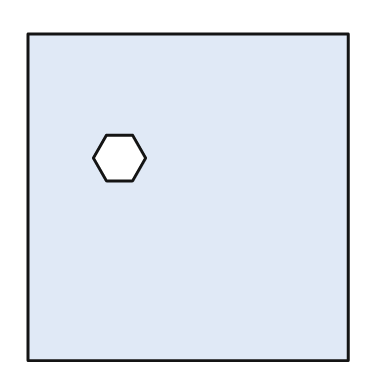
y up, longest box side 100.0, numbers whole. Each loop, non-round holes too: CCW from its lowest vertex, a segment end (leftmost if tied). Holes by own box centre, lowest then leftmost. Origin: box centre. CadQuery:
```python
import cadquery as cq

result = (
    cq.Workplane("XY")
    .moveTo(-49.0, -50.0)
    .lineTo(49.0, -50.0)
    .lineTo(49.0, 50.0)
    .lineTo(-49.0, 50.0)
    .close()
    .moveTo(-25.0, 5.0)
    .lineTo(-17.0, 5.0)
    .lineTo(-13.0, 12.0)
    .lineTo(-17.0, 19.0)
    .lineTo(-25.0, 19.0)
    .lineTo(-29.0, 12.0)
    .close()
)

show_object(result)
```